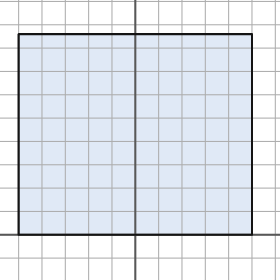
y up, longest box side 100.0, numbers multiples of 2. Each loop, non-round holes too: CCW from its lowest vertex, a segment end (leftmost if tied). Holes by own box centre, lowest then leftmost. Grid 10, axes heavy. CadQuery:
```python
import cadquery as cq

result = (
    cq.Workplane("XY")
    .moveTo(-50.0, 0.0)
    .lineTo(50.0, 0.0)
    .lineTo(50.0, 86.0)
    .lineTo(-50.0, 86.0)
    .close()
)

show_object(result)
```